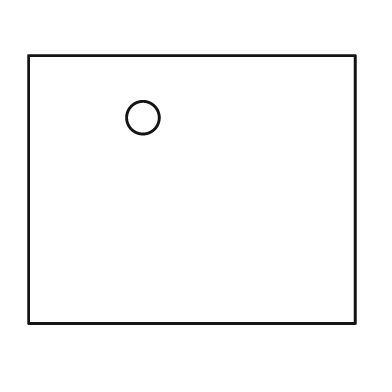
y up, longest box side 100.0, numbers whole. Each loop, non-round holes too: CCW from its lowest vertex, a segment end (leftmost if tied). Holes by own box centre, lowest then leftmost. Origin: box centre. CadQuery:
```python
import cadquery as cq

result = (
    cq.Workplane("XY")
    .moveTo(-50.0, -41.0)
    .lineTo(50.0, -41.0)
    .lineTo(50.0, 41.0)
    .lineTo(-50.0, 41.0)
    .close()
    .moveTo(-15.0, 22.0)
    .circle(5.0)
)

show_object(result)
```